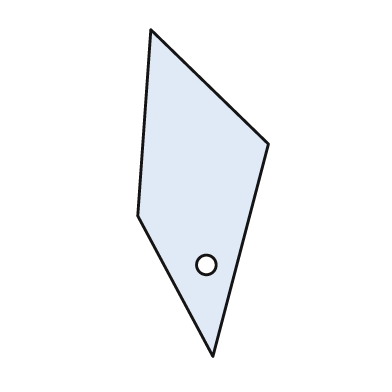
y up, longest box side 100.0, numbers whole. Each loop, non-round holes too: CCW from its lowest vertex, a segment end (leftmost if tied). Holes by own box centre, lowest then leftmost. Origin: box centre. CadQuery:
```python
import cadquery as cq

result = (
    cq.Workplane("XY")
    .moveTo(3.0, -50.0)
    .lineTo(20.0, 15.0)
    .lineTo(-16.0, 50.0)
    .lineTo(-20.0, -7.0)
    .close()
    .moveTo(1.0, -22.0)
    .circle(3.0)
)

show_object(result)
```